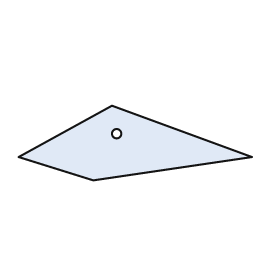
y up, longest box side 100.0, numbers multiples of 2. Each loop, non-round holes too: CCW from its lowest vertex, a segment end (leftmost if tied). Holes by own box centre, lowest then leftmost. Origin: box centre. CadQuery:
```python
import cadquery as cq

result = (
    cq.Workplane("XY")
    .moveTo(-18.0, -16.0)
    .lineTo(50.0, -6.0)
    .lineTo(-10.0, 16.0)
    .lineTo(-50.0, -6.0)
    .close()
    .moveTo(-8.0, 4.0)
    .circle(2.0)
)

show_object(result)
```